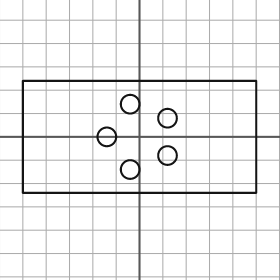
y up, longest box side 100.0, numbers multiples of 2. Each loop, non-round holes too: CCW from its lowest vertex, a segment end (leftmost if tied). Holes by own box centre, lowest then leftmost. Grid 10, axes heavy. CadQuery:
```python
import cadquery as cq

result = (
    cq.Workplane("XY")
    .moveTo(-50.0, -24.0)
    .lineTo(50.0, -24.0)
    .lineTo(50.0, 24.0)
    .lineTo(-50.0, 24.0)
    .close()
    .moveTo(-4.0, -14.0)
    .circle(4.0)
    .moveTo(12.0, -8.0)
    .circle(4.0)
    .moveTo(-14.0, 0.0)
    .circle(4.0)
    .moveTo(12.0, 8.0)
    .circle(4.0)
    .moveTo(-4.0, 14.0)
    .circle(4.0)
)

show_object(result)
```